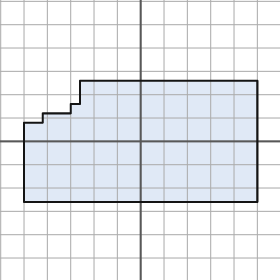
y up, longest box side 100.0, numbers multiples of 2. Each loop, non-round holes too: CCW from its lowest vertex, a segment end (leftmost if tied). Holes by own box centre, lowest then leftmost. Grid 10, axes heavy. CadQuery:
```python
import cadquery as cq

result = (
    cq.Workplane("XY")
    .moveTo(-50.0, -26.0)
    .lineTo(50.0, -26.0)
    .lineTo(50.0, 26.0)
    .lineTo(-26.0, 26.0)
    .lineTo(-26.0, 16.0)
    .lineTo(-30.0, 16.0)
    .lineTo(-30.0, 12.0)
    .lineTo(-42.0, 12.0)
    .lineTo(-42.0, 8.0)
    .lineTo(-50.0, 8.0)
    .close()
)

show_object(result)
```